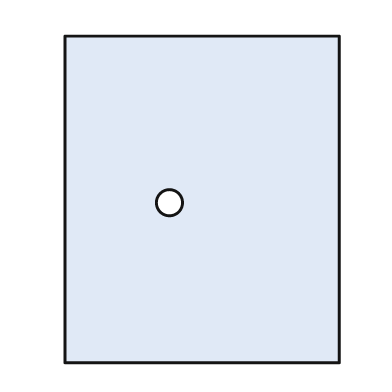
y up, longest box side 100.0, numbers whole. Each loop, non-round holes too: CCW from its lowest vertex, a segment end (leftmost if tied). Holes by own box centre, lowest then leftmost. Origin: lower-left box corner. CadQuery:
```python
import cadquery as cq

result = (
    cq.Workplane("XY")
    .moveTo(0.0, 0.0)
    .lineTo(84.0, 0.0)
    .lineTo(84.0, 100.0)
    .lineTo(0.0, 100.0)
    .close()
    .moveTo(32.0, 49.0)
    .circle(4.0)
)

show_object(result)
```